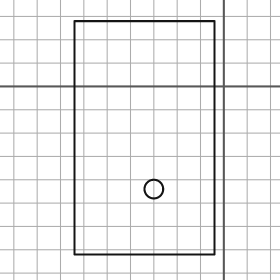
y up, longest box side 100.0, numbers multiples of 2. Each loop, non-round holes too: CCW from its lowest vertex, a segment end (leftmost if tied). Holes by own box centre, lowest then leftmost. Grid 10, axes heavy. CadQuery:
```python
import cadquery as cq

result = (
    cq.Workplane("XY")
    .moveTo(-64.0, -72.0)
    .lineTo(-4.0, -72.0)
    .lineTo(-4.0, 28.0)
    .lineTo(-64.0, 28.0)
    .close()
    .moveTo(-30.0, -44.0)
    .circle(4.0)
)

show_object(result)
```